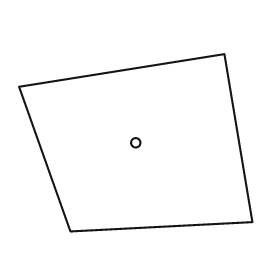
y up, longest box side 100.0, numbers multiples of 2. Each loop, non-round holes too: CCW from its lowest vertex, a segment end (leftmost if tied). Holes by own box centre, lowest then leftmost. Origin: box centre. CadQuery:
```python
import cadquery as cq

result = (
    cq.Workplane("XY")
    .moveTo(-28.0, -38.0)
    .lineTo(50.0, -34.0)
    .lineTo(38.0, 38.0)
    .lineTo(-50.0, 24.0)
    .close()
    .moveTo(0.0, 0.0)
    .circle(2.0)
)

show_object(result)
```